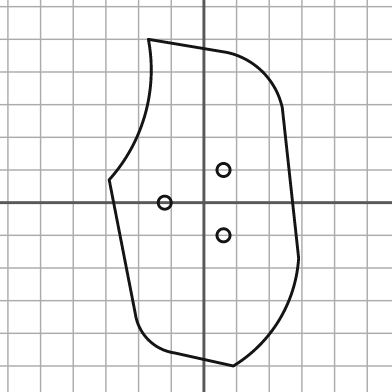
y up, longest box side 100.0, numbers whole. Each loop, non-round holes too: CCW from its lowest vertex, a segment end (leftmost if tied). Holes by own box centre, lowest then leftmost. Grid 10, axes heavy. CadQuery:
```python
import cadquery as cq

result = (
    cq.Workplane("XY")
    .moveTo(9.0, -50.0)
    .threePointArc((23.0, -36.0), (29.0, -17.0))
    .lineTo(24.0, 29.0)
    .threePointArc((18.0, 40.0), (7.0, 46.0))
    .lineTo(-17.0, 50.0)
    .threePointArc((-18.0, 27.0), (-29.0, 7.0))
    .lineTo(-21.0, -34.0)
    .threePointArc((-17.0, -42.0), (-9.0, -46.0))
    .close()
    .moveTo(6.0, -10.0)
    .circle(2.0)
    .moveTo(-12.0, 0.0)
    .circle(2.0)
    .moveTo(6.0, 10.0)
    .circle(2.0)
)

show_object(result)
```